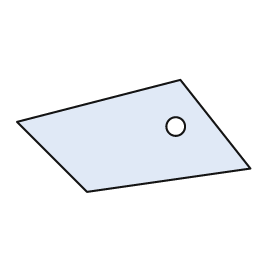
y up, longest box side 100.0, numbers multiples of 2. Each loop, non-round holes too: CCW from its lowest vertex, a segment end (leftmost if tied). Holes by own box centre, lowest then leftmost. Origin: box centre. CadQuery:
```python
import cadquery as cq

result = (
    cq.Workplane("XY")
    .moveTo(-20.0, -24.0)
    .lineTo(50.0, -14.0)
    .lineTo(20.0, 24.0)
    .lineTo(-50.0, 6.0)
    .close()
    .moveTo(18.0, 4.0)
    .circle(4.0)
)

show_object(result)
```